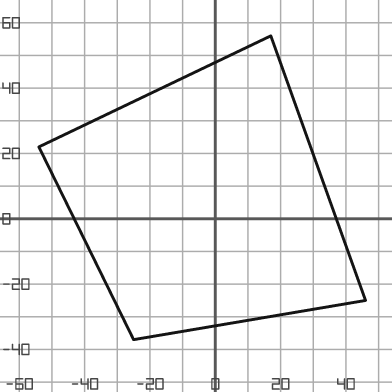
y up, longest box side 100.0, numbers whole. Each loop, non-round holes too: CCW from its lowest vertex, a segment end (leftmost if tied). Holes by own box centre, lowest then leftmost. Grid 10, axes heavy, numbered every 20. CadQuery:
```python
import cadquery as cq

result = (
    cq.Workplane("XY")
    .moveTo(-25.0, -37.0)
    .lineTo(46.0, -25.0)
    .lineTo(17.0, 56.0)
    .lineTo(-54.0, 22.0)
    .close()
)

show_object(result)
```